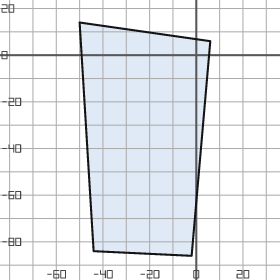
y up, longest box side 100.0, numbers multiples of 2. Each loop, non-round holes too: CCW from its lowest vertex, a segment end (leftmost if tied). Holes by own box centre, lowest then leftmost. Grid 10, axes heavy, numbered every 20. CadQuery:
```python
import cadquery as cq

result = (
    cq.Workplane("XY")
    .moveTo(-2.0, -86.0)
    .lineTo(6.0, 6.0)
    .lineTo(-50.0, 14.0)
    .lineTo(-44.0, -84.0)
    .close()
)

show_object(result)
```